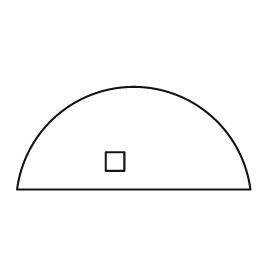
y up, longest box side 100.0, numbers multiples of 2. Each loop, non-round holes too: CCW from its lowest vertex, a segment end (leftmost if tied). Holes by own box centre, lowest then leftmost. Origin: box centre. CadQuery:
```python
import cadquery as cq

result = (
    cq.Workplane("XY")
    .moveTo(-50.0, -22.0)
    .lineTo(50.0, -22.0)
    .threePointArc((0.0, 22.0), (-50.0, -22.0))
    .close()
    .moveTo(-12.0, -14.0)
    .lineTo(-4.0, -14.0)
    .lineTo(-4.0, -6.0)
    .lineTo(-12.0, -6.0)
    .close()
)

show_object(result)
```